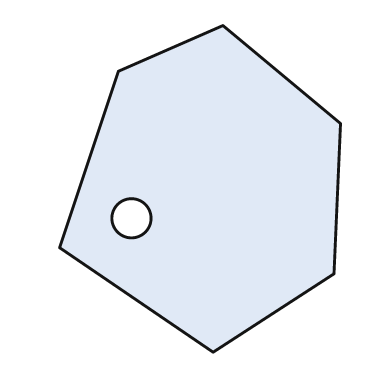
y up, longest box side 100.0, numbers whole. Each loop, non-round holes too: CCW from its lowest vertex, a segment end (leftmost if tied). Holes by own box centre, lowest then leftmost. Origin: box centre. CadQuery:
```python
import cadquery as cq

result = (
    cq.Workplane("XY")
    .moveTo(4.0, -50.0)
    .lineTo(41.0, -26.0)
    .lineTo(43.0, 20.0)
    .lineTo(7.0, 50.0)
    .lineTo(-25.0, 36.0)
    .lineTo(-43.0, -18.0)
    .close()
    .moveTo(-21.0, -9.0)
    .circle(6.0)
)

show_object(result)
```